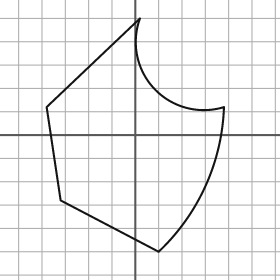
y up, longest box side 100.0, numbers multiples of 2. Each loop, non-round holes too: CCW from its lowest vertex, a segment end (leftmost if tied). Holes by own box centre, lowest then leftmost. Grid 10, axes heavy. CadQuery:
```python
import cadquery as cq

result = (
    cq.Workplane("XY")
    .moveTo(10.0, -50.0)
    .threePointArc((30.0, -22.0), (38.0, 12.0))
    .threePointArc((8.0, 20.0), (2.0, 50.0))
    .lineTo(-38.0, 12.0)
    .lineTo(-32.0, -28.0)
    .close()
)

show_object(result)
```